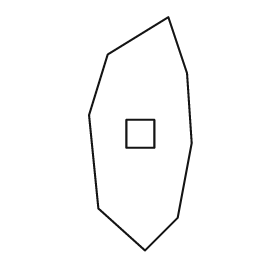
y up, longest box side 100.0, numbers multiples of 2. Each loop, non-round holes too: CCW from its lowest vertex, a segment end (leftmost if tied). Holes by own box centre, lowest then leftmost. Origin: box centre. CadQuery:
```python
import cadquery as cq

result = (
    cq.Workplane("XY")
    .moveTo(2.0, -50.0)
    .lineTo(16.0, -36.0)
    .lineTo(22.0, -4.0)
    .lineTo(20.0, 26.0)
    .lineTo(12.0, 50.0)
    .lineTo(-14.0, 34.0)
    .lineTo(-22.0, 8.0)
    .lineTo(-18.0, -32.0)
    .close()
    .moveTo(-6.0, -6.0)
    .lineTo(6.0, -6.0)
    .lineTo(6.0, 6.0)
    .lineTo(-6.0, 6.0)
    .close()
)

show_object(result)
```